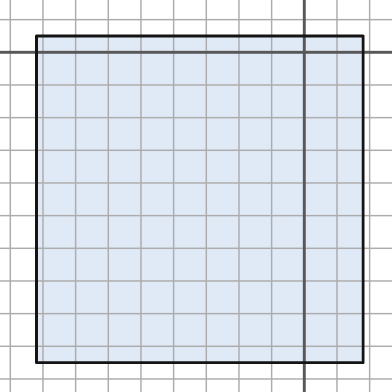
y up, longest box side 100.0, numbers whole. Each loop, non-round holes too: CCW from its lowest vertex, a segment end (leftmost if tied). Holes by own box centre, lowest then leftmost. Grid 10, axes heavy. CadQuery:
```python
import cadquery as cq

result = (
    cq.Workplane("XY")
    .moveTo(-82.0, -95.0)
    .lineTo(18.0, -95.0)
    .lineTo(18.0, 5.0)
    .lineTo(-82.0, 5.0)
    .close()
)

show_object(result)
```